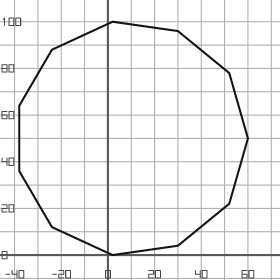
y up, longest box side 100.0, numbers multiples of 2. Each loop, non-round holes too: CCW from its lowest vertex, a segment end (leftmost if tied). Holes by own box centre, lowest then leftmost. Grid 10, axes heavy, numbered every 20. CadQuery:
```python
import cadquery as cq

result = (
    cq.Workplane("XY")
    .moveTo(2.0, 0.0)
    .lineTo(30.0, 4.0)
    .lineTo(52.0, 22.0)
    .lineTo(60.0, 50.0)
    .lineTo(52.0, 78.0)
    .lineTo(30.0, 96.0)
    .lineTo(2.0, 100.0)
    .lineTo(-24.0, 88.0)
    .lineTo(-38.0, 64.0)
    .lineTo(-38.0, 36.0)
    .lineTo(-24.0, 12.0)
    .close()
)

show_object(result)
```